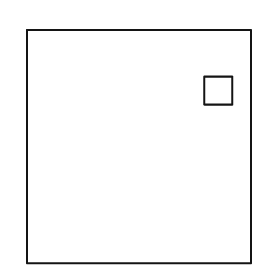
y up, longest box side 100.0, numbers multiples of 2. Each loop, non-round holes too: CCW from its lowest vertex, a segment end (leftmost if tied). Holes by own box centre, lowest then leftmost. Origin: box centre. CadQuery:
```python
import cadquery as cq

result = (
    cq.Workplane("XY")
    .moveTo(-48.0, -50.0)
    .lineTo(48.0, -50.0)
    .lineTo(48.0, 50.0)
    .lineTo(-48.0, 50.0)
    .close()
    .moveTo(28.0, 18.0)
    .lineTo(40.0, 18.0)
    .lineTo(40.0, 30.0)
    .lineTo(28.0, 30.0)
    .close()
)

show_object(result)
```